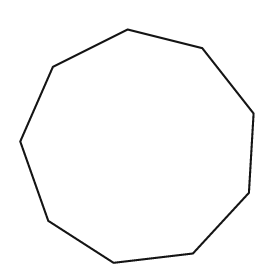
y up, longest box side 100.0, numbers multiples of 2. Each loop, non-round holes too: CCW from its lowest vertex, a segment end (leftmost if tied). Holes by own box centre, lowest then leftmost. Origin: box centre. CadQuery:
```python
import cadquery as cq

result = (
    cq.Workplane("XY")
    .moveTo(-10.0, -50.0)
    .lineTo(24.0, -46.0)
    .lineTo(48.0, -20.0)
    .lineTo(50.0, 14.0)
    .lineTo(28.0, 42.0)
    .lineTo(-4.0, 50.0)
    .lineTo(-36.0, 34.0)
    .lineTo(-50.0, 2.0)
    .lineTo(-38.0, -32.0)
    .close()
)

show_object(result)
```